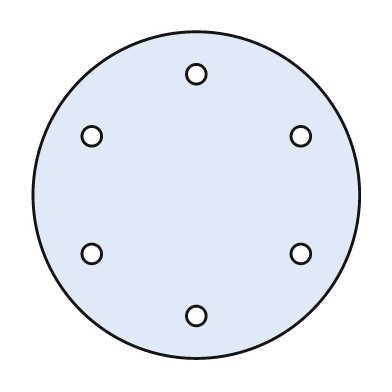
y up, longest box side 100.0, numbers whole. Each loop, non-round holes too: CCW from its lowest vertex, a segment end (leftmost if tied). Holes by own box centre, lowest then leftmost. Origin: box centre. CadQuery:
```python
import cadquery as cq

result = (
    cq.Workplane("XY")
    .moveTo(0.0, 0.0)
    .circle(50.0)
    .moveTo(0.0, -37.0)
    .circle(3.0)
    .moveTo(-32.0, -18.0)
    .circle(3.0)
    .moveTo(32.0, -18.0)
    .circle(3.0)
    .moveTo(-32.0, 18.0)
    .circle(3.0)
    .moveTo(32.0, 18.0)
    .circle(3.0)
    .moveTo(0.0, 37.0)
    .circle(3.0)
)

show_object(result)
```